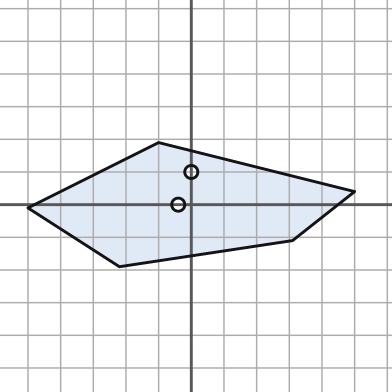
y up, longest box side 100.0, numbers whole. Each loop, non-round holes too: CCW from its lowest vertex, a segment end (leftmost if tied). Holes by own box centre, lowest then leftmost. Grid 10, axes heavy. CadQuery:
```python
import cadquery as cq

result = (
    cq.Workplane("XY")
    .moveTo(-22.0, -19.0)
    .lineTo(31.0, -11.0)
    .lineTo(50.0, 4.0)
    .lineTo(-10.0, 19.0)
    .lineTo(-50.0, -1.0)
    .close()
    .moveTo(-4.0, 0.0)
    .circle(2.0)
    .moveTo(0.0, 10.0)
    .circle(2.0)
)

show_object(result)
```